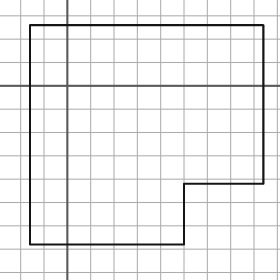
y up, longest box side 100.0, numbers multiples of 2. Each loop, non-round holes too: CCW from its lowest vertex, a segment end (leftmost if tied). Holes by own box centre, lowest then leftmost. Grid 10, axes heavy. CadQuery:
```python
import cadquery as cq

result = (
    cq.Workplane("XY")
    .moveTo(-16.0, -68.0)
    .lineTo(50.0, -68.0)
    .lineTo(50.0, -42.0)
    .lineTo(84.0, -42.0)
    .lineTo(84.0, 26.0)
    .lineTo(-16.0, 26.0)
    .close()
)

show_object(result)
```